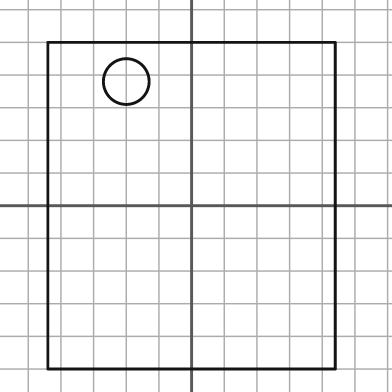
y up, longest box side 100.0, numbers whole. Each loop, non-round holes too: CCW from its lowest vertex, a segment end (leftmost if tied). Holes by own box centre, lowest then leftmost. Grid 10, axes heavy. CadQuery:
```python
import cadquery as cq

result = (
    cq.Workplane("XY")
    .moveTo(-44.0, -50.0)
    .lineTo(44.0, -50.0)
    .lineTo(44.0, 50.0)
    .lineTo(-44.0, 50.0)
    .close()
    .moveTo(-20.0, 38.0)
    .circle(7.0)
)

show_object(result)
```